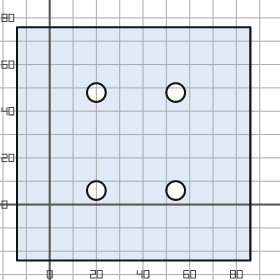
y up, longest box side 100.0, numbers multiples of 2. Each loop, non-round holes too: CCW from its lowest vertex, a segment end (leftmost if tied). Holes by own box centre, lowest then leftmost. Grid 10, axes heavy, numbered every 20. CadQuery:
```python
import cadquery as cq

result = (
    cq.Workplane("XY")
    .moveTo(-14.0, -24.0)
    .lineTo(86.0, -24.0)
    .lineTo(86.0, 76.0)
    .lineTo(-14.0, 76.0)
    .close()
    .moveTo(20.0, 6.0)
    .circle(4.0)
    .moveTo(54.0, 6.0)
    .circle(4.0)
    .moveTo(20.0, 48.0)
    .circle(4.0)
    .moveTo(54.0, 48.0)
    .circle(4.0)
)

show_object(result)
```